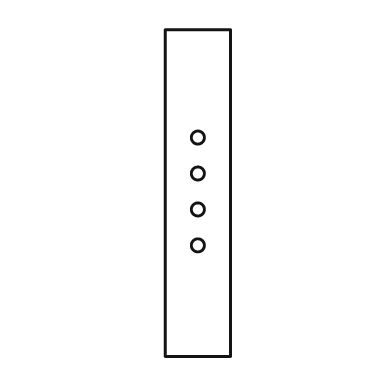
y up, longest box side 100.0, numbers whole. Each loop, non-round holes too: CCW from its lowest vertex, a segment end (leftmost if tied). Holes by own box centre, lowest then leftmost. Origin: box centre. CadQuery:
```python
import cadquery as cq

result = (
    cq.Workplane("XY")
    .moveTo(-10.0, -50.0)
    .lineTo(10.0, -50.0)
    .lineTo(10.0, 50.0)
    .lineTo(-10.0, 50.0)
    .close()
    .moveTo(0.0, -16.0)
    .circle(2.0)
    .moveTo(0.0, -5.0)
    .circle(2.0)
    .moveTo(0.0, 6.0)
    .circle(2.0)
    .moveTo(0.0, 17.0)
    .circle(2.0)
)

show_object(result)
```